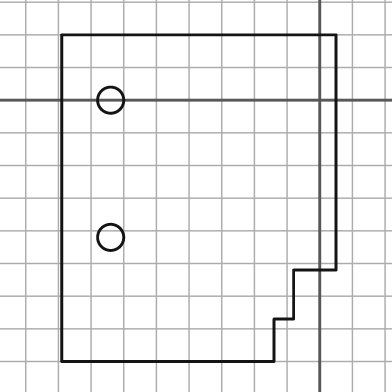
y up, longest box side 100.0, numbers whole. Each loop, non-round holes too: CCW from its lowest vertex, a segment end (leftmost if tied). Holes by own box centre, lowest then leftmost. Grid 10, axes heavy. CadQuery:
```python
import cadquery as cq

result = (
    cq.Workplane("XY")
    .moveTo(-79.0, -80.0)
    .lineTo(-14.0, -80.0)
    .lineTo(-14.0, -67.0)
    .lineTo(-8.0, -67.0)
    .lineTo(-8.0, -52.0)
    .lineTo(5.0, -52.0)
    .lineTo(5.0, 20.0)
    .lineTo(-79.0, 20.0)
    .close()
    .moveTo(-64.0, -42.0)
    .circle(4.0)
    .moveTo(-64.0, 0.0)
    .circle(4.0)
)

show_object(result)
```